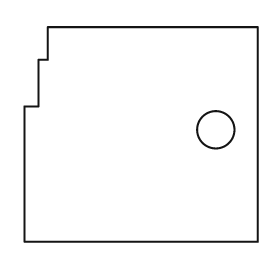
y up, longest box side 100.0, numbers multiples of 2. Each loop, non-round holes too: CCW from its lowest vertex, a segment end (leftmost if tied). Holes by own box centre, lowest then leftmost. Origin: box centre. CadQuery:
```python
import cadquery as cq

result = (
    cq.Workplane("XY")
    .moveTo(-50.0, -46.0)
    .lineTo(50.0, -46.0)
    .lineTo(50.0, 46.0)
    .lineTo(-40.0, 46.0)
    .lineTo(-40.0, 32.0)
    .lineTo(-44.0, 32.0)
    .lineTo(-44.0, 12.0)
    .lineTo(-50.0, 12.0)
    .close()
    .moveTo(32.0, 2.0)
    .circle(8.0)
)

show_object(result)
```